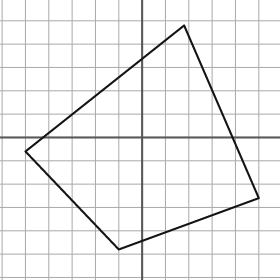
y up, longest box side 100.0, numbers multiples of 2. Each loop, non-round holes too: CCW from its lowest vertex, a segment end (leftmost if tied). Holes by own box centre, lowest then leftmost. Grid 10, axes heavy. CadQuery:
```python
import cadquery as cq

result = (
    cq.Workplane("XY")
    .moveTo(-10.0, -48.0)
    .lineTo(50.0, -26.0)
    .lineTo(18.0, 48.0)
    .lineTo(-50.0, -6.0)
    .close()
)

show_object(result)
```